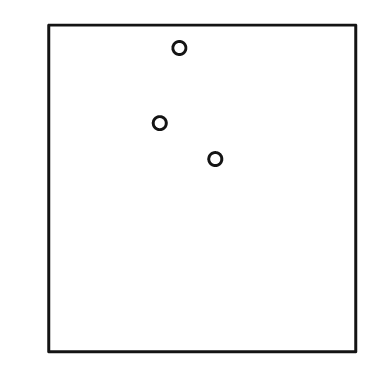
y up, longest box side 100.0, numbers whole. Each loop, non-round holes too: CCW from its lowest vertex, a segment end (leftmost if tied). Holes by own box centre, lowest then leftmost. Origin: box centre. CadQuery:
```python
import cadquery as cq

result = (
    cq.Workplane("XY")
    .moveTo(-47.0, -50.0)
    .lineTo(47.0, -50.0)
    .lineTo(47.0, 50.0)
    .lineTo(-47.0, 50.0)
    .close()
    .moveTo(4.0, 9.0)
    .circle(2.0)
    .moveTo(-13.0, 20.0)
    .circle(2.0)
    .moveTo(-7.0, 43.0)
    .circle(2.0)
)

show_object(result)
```